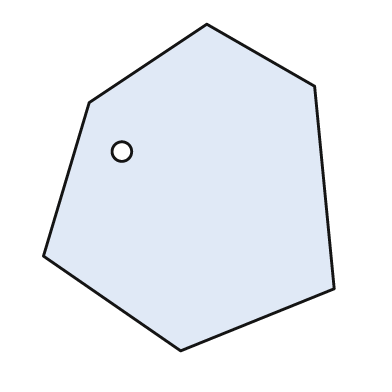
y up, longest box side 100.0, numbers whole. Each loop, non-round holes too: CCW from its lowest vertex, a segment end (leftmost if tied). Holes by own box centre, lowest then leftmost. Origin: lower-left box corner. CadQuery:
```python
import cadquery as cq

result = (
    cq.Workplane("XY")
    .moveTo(42.0, 0.0)
    .lineTo(89.0, 19.0)
    .lineTo(83.0, 81.0)
    .lineTo(50.0, 100.0)
    .lineTo(14.0, 76.0)
    .lineTo(0.0, 29.0)
    .close()
    .moveTo(24.0, 61.0)
    .circle(3.0)
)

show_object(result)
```